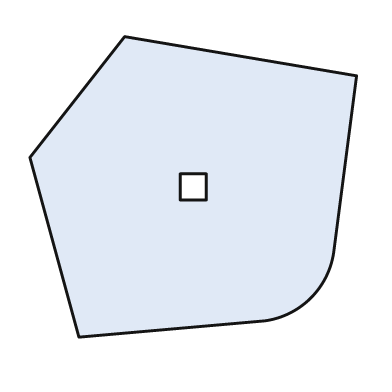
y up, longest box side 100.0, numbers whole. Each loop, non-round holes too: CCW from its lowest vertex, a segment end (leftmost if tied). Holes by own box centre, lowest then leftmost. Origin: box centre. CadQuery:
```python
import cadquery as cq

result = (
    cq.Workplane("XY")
    .moveTo(-35.0, -46.0)
    .lineTo(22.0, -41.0)
    .threePointArc((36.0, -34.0), (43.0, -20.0))
    .lineTo(50.0, 34.0)
    .lineTo(-21.0, 46.0)
    .lineTo(-50.0, 9.0)
    .close()
    .moveTo(-4.0, -4.0)
    .lineTo(4.0, -4.0)
    .lineTo(4.0, 4.0)
    .lineTo(-4.0, 4.0)
    .close()
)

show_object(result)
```